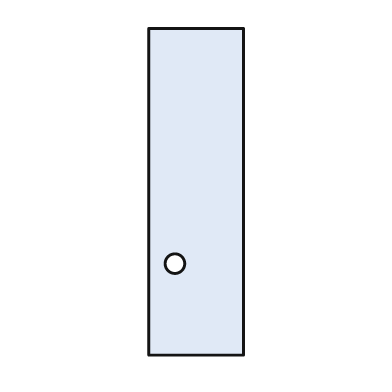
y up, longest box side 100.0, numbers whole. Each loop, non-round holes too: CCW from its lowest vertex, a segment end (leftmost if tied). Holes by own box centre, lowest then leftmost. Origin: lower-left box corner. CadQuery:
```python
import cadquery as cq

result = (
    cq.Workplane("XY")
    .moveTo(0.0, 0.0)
    .lineTo(29.0, 0.0)
    .lineTo(29.0, 100.0)
    .lineTo(0.0, 100.0)
    .close()
    .moveTo(8.0, 28.0)
    .circle(3.0)
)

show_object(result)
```